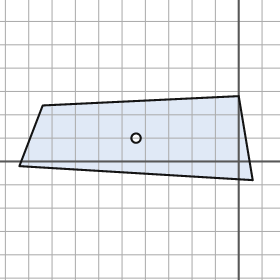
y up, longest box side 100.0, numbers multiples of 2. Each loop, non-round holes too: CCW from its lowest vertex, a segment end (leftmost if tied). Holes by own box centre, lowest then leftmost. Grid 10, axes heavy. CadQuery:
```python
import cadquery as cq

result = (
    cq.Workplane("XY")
    .moveTo(6.0, -8.0)
    .lineTo(0.0, 28.0)
    .lineTo(-84.0, 24.0)
    .lineTo(-94.0, -2.0)
    .close()
    .moveTo(-44.0, 10.0)
    .circle(2.0)
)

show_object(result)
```